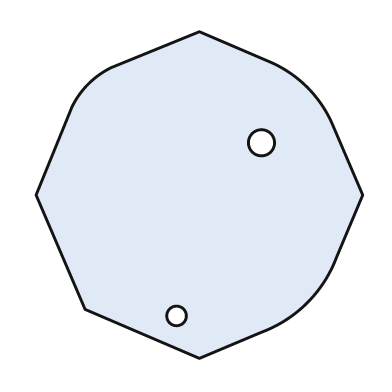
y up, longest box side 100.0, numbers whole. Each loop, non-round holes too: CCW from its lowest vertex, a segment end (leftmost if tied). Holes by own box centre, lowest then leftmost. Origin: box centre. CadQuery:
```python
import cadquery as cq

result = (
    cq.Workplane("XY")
    .moveTo(0.0, -50.0)
    .lineTo(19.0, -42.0)
    .threePointArc((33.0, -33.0), (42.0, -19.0))
    .lineTo(50.0, 0.0)
    .lineTo(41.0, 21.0)
    .threePointArc((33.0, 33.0), (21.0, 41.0))
    .lineTo(0.0, 50.0)
    .lineTo(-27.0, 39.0)
    .threePointArc((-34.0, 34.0), (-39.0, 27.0))
    .lineTo(-50.0, 0.0)
    .lineTo(-35.0, -35.0)
    .close()
    .moveTo(-7.0, -37.0)
    .circle(3.0)
    .moveTo(19.0, 16.0)
    .circle(4.0)
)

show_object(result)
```